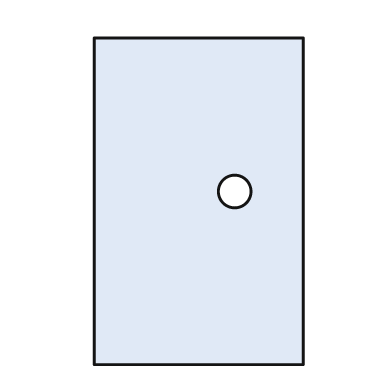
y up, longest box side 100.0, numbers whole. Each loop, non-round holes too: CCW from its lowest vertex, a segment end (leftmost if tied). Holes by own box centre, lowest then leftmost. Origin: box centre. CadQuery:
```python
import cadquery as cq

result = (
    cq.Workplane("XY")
    .moveTo(-32.0, -50.0)
    .lineTo(32.0, -50.0)
    .lineTo(32.0, 50.0)
    .lineTo(-32.0, 50.0)
    .close()
    .moveTo(11.0, 3.0)
    .circle(5.0)
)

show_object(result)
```